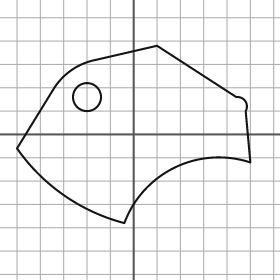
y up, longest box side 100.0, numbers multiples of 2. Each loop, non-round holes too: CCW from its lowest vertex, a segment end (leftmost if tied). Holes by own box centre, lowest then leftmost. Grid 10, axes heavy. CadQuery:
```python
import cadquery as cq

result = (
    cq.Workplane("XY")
    .moveTo(-4.0, -38.0)
    .threePointArc((18.0, -14.0), (50.0, -12.0))
    .lineTo(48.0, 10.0)
    .threePointArc((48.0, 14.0), (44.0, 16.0))
    .lineTo(10.0, 38.0)
    .lineTo(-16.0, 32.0)
    .threePointArc((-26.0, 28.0), (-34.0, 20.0))
    .lineTo(-50.0, -6.0)
    .threePointArc((-30.0, -26.0), (-4.0, -38.0))
    .close()
    .moveTo(-20.0, 16.0)
    .circle(6.0)
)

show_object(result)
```